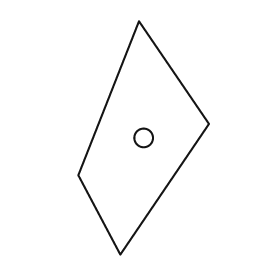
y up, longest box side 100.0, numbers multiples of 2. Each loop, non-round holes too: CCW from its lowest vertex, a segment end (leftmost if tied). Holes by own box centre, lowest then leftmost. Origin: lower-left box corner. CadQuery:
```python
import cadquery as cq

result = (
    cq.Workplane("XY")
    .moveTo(18.0, 0.0)
    .lineTo(56.0, 56.0)
    .lineTo(26.0, 100.0)
    .lineTo(0.0, 34.0)
    .close()
    .moveTo(28.0, 50.0)
    .circle(4.0)
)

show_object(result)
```